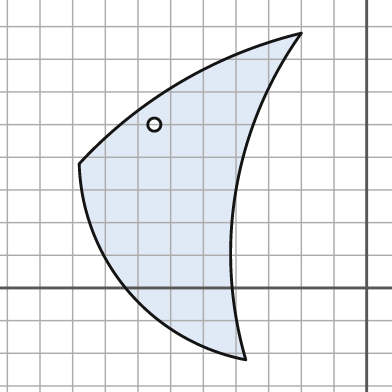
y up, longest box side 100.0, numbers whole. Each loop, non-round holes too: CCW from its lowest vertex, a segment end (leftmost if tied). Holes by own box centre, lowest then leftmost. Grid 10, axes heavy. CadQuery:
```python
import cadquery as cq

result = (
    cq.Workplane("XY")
    .moveTo(-37.0, -22.0)
    .threePointArc((-40.0, 30.0), (-20.0, 78.0))
    .threePointArc((-57.0, 63.0), (-88.0, 38.0))
    .threePointArc((-73.0, -1.0), (-37.0, -22.0))
    .close()
    .moveTo(-65.0, 50.0)
    .circle(2.0)
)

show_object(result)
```